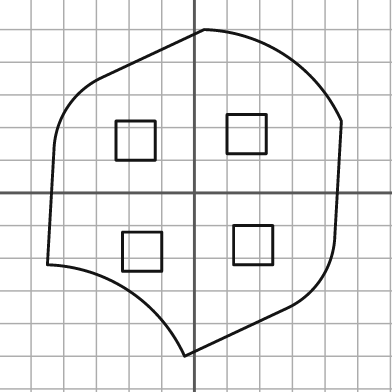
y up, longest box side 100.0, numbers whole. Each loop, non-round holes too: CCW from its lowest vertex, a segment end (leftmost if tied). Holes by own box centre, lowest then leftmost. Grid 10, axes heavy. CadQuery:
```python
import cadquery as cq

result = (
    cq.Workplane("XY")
    .moveTo(-3.0, -50.0)
    .lineTo(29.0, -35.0)
    .threePointArc((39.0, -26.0), (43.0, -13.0))
    .lineTo(45.0, 22.0)
    .threePointArc((28.0, 42.0), (3.0, 50.0))
    .lineTo(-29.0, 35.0)
    .threePointArc((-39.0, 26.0), (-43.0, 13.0))
    .lineTo(-45.0, -22.0)
    .threePointArc((-20.0, -30.0), (-3.0, -50.0))
    .close()
    .moveTo(-22.0, -24.0)
    .lineTo(-10.0, -24.0)
    .lineTo(-10.0, -12.0)
    .lineTo(-22.0, -12.0)
    .close()
    .moveTo(12.0, -22.0)
    .lineTo(24.0, -22.0)
    .lineTo(24.0, -10.0)
    .lineTo(12.0, -10.0)
    .close()
    .moveTo(-24.0, 10.0)
    .lineTo(-12.0, 10.0)
    .lineTo(-12.0, 22.0)
    .lineTo(-24.0, 22.0)
    .close()
    .moveTo(10.0, 12.0)
    .lineTo(22.0, 12.0)
    .lineTo(22.0, 24.0)
    .lineTo(10.0, 24.0)
    .close()
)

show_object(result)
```